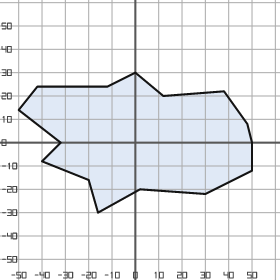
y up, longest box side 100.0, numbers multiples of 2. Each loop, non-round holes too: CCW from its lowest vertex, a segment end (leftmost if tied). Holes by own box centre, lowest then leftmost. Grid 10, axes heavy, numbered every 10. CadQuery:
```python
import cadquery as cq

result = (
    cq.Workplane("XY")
    .moveTo(-16.0, -30.0)
    .lineTo(2.0, -20.0)
    .lineTo(30.0, -22.0)
    .lineTo(50.0, -12.0)
    .lineTo(50.0, 0.0)
    .lineTo(48.0, 8.0)
    .lineTo(38.0, 22.0)
    .lineTo(12.0, 20.0)
    .lineTo(0.0, 30.0)
    .lineTo(-12.0, 24.0)
    .lineTo(-42.0, 24.0)
    .lineTo(-50.0, 14.0)
    .lineTo(-32.0, 0.0)
    .lineTo(-40.0, -8.0)
    .lineTo(-20.0, -16.0)
    .close()
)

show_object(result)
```